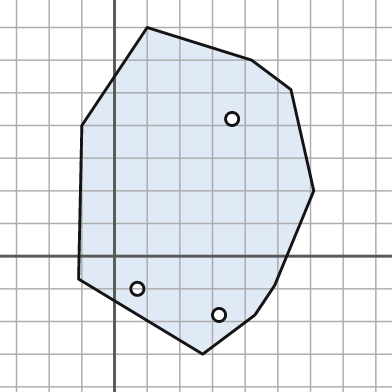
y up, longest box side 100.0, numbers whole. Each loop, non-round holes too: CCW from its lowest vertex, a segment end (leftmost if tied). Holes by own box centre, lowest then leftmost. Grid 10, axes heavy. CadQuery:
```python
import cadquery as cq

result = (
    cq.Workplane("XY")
    .moveTo(27.0, -30.0)
    .lineTo(43.0, -18.0)
    .lineTo(49.0, -9.0)
    .lineTo(61.0, 20.0)
    .lineTo(54.0, 51.0)
    .lineTo(42.0, 60.0)
    .lineTo(10.0, 70.0)
    .lineTo(-10.0, 40.0)
    .lineTo(-11.0, -7.0)
    .close()
    .moveTo(32.0, -18.0)
    .circle(2.0)
    .moveTo(7.0, -10.0)
    .circle(2.0)
    .moveTo(36.0, 42.0)
    .circle(2.0)
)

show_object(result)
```